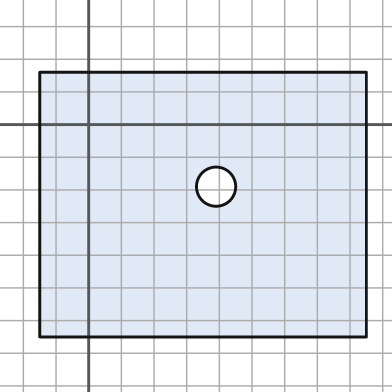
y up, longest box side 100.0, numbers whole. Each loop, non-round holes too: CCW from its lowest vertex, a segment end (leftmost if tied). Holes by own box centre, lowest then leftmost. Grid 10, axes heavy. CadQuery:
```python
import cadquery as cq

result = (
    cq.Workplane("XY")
    .moveTo(-15.0, -65.0)
    .lineTo(85.0, -65.0)
    .lineTo(85.0, 16.0)
    .lineTo(-15.0, 16.0)
    .close()
    .moveTo(39.0, -19.0)
    .circle(6.0)
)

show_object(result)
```